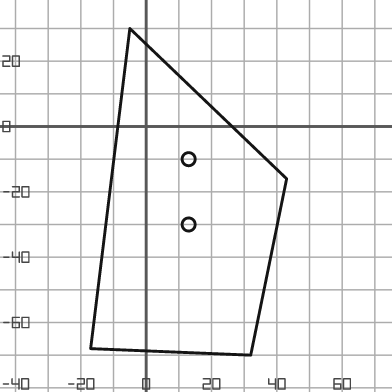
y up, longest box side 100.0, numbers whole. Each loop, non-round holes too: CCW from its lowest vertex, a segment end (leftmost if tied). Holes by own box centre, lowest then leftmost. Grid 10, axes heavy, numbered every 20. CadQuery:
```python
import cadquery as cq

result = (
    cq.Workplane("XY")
    .moveTo(32.0, -70.0)
    .lineTo(43.0, -16.0)
    .lineTo(-5.0, 30.0)
    .lineTo(-17.0, -68.0)
    .close()
    .moveTo(13.0, -30.0)
    .circle(2.0)
    .moveTo(13.0, -10.0)
    .circle(2.0)
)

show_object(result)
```